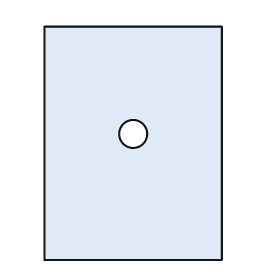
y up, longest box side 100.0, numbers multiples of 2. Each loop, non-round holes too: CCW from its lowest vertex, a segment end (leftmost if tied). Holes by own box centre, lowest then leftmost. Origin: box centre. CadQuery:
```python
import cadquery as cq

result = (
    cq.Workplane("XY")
    .moveTo(-38.0, -50.0)
    .lineTo(38.0, -50.0)
    .lineTo(38.0, 50.0)
    .lineTo(-38.0, 50.0)
    .close()
    .moveTo(0.0, 4.0)
    .circle(6.0)
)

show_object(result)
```